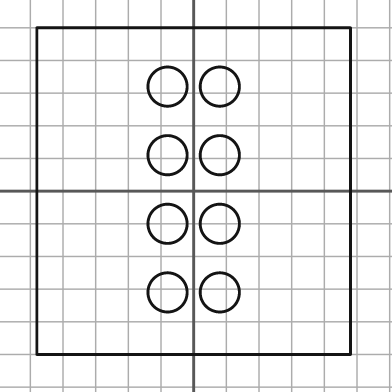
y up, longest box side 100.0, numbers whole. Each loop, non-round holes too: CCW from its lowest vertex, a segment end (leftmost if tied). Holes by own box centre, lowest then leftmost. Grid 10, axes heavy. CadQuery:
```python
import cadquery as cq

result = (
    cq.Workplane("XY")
    .moveTo(-48.0, -50.0)
    .lineTo(48.0, -50.0)
    .lineTo(48.0, 50.0)
    .lineTo(-48.0, 50.0)
    .close()
    .moveTo(-8.0, -31.0)
    .circle(6.0)
    .moveTo(8.0, -31.0)
    .circle(6.0)
    .moveTo(-8.0, -10.0)
    .circle(6.0)
    .moveTo(8.0, -10.0)
    .circle(6.0)
    .moveTo(-8.0, 11.0)
    .circle(6.0)
    .moveTo(8.0, 11.0)
    .circle(6.0)
    .moveTo(-8.0, 32.0)
    .circle(6.0)
    .moveTo(8.0, 32.0)
    .circle(6.0)
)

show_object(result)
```